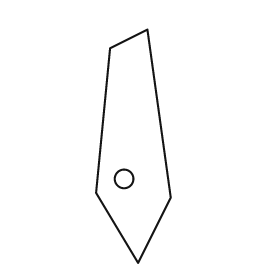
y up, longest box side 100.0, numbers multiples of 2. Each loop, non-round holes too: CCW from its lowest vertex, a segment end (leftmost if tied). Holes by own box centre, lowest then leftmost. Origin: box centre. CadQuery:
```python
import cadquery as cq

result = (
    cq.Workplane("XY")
    .moveTo(2.0, -50.0)
    .lineTo(16.0, -22.0)
    .lineTo(6.0, 50.0)
    .lineTo(-10.0, 42.0)
    .lineTo(-16.0, -20.0)
    .close()
    .moveTo(-4.0, -14.0)
    .circle(4.0)
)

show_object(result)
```